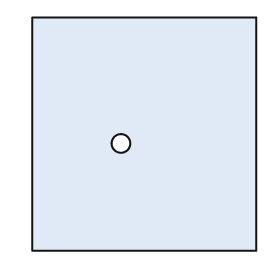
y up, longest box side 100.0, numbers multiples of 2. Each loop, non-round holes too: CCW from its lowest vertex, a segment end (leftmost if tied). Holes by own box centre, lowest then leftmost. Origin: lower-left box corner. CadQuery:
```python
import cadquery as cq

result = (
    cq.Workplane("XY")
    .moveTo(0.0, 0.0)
    .lineTo(96.0, 0.0)
    .lineTo(96.0, 100.0)
    .lineTo(0.0, 100.0)
    .close()
    .moveTo(38.0, 46.0)
    .circle(4.0)
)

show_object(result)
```